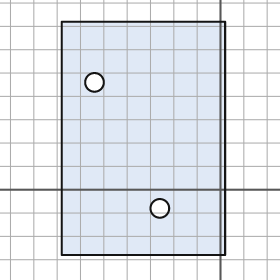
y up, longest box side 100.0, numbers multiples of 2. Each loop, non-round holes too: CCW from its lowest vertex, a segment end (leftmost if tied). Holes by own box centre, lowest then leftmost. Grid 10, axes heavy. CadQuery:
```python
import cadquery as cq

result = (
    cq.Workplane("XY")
    .moveTo(-68.0, -28.0)
    .lineTo(2.0, -28.0)
    .lineTo(2.0, 72.0)
    .lineTo(-68.0, 72.0)
    .close()
    .moveTo(-26.0, -8.0)
    .circle(4.0)
    .moveTo(-54.0, 46.0)
    .circle(4.0)
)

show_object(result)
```